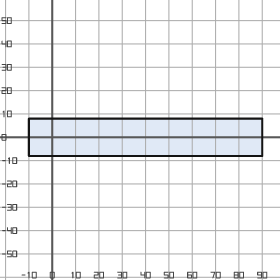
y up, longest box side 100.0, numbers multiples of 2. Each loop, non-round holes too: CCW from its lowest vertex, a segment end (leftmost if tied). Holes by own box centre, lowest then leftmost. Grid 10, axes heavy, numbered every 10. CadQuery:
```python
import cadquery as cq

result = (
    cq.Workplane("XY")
    .moveTo(-10.0, -8.0)
    .lineTo(90.0, -8.0)
    .lineTo(90.0, 8.0)
    .lineTo(-10.0, 8.0)
    .close()
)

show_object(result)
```